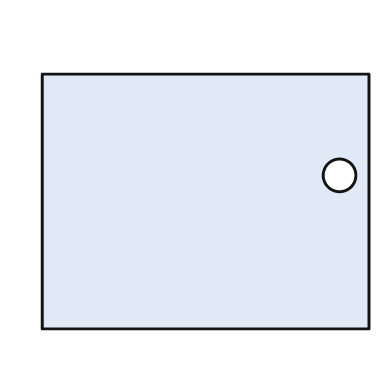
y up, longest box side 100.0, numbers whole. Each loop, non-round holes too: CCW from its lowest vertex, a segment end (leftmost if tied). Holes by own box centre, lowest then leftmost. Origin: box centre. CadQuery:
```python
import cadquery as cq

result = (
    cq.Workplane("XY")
    .moveTo(-50.0, -39.0)
    .lineTo(50.0, -39.0)
    .lineTo(50.0, 39.0)
    .lineTo(-50.0, 39.0)
    .close()
    .moveTo(41.0, 8.0)
    .circle(5.0)
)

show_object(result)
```